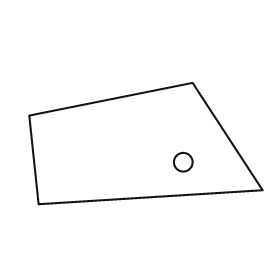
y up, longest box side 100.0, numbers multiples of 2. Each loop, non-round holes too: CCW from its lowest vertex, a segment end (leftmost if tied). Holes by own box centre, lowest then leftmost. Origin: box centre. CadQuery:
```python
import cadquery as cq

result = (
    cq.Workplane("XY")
    .moveTo(-46.0, -26.0)
    .lineTo(50.0, -20.0)
    .lineTo(20.0, 26.0)
    .lineTo(-50.0, 12.0)
    .close()
    .moveTo(16.0, -8.0)
    .circle(4.0)
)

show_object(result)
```